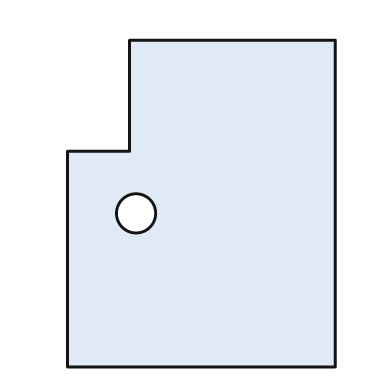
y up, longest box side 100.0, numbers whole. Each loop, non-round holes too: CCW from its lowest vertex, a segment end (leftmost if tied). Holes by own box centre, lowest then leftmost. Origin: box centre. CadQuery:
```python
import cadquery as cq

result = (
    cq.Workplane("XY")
    .moveTo(-41.0, -50.0)
    .lineTo(41.0, -50.0)
    .lineTo(41.0, 50.0)
    .lineTo(-22.0, 50.0)
    .lineTo(-22.0, 16.0)
    .lineTo(-41.0, 16.0)
    .close()
    .moveTo(-20.0, -3.0)
    .circle(6.0)
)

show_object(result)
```